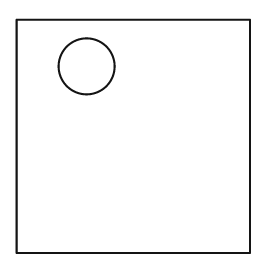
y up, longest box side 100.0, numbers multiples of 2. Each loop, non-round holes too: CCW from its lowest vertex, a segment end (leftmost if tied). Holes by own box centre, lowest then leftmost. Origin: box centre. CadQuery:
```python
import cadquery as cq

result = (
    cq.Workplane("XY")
    .moveTo(-50.0, -50.0)
    .lineTo(50.0, -50.0)
    .lineTo(50.0, 50.0)
    .lineTo(-50.0, 50.0)
    .close()
    .moveTo(-20.0, 30.0)
    .circle(12.0)
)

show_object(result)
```